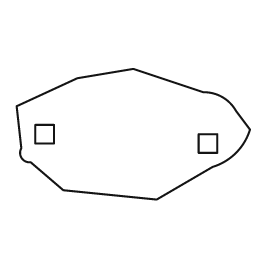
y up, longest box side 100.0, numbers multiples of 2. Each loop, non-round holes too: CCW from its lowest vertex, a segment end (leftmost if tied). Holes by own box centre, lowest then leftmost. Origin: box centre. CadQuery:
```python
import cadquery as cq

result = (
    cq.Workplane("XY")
    .moveTo(10.0, -28.0)
    .lineTo(34.0, -14.0)
    .threePointArc((44.0, -8.0), (50.0, 2.0))
    .lineTo(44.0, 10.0)
    .threePointArc((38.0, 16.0), (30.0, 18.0))
    .lineTo(0.0, 28.0)
    .lineTo(-24.0, 24.0)
    .lineTo(-50.0, 12.0)
    .lineTo(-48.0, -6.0)
    .threePointArc((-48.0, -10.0), (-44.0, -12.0))
    .lineTo(-30.0, -24.0)
    .close()
    .moveTo(28.0, -8.0)
    .lineTo(36.0, -8.0)
    .lineTo(36.0, 0.0)
    .lineTo(28.0, 0.0)
    .close()
    .moveTo(-42.0, -4.0)
    .lineTo(-34.0, -4.0)
    .lineTo(-34.0, 4.0)
    .lineTo(-42.0, 4.0)
    .close()
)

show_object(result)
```